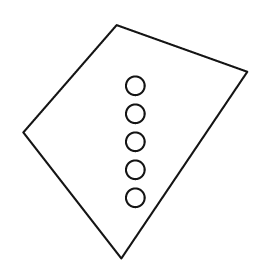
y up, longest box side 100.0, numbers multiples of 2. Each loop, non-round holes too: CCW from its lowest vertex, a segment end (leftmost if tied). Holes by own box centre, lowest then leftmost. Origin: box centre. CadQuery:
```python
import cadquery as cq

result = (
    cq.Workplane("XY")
    .moveTo(-6.0, -50.0)
    .lineTo(48.0, 30.0)
    .lineTo(-8.0, 50.0)
    .lineTo(-48.0, 4.0)
    .close()
    .moveTo(0.0, -24.0)
    .circle(4.0)
    .moveTo(0.0, -12.0)
    .circle(4.0)
    .moveTo(0.0, 0.0)
    .circle(4.0)
    .moveTo(0.0, 12.0)
    .circle(4.0)
    .moveTo(0.0, 24.0)
    .circle(4.0)
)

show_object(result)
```